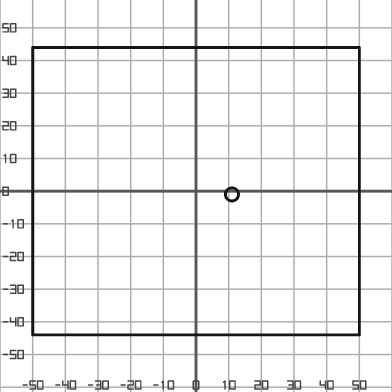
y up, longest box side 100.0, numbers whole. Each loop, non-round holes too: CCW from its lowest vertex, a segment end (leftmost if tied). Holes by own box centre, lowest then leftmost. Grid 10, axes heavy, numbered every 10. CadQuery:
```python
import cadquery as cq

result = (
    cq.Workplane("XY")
    .moveTo(-50.0, -44.0)
    .lineTo(50.0, -44.0)
    .lineTo(50.0, 44.0)
    .lineTo(-50.0, 44.0)
    .close()
    .moveTo(11.0, -1.0)
    .circle(2.0)
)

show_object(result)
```